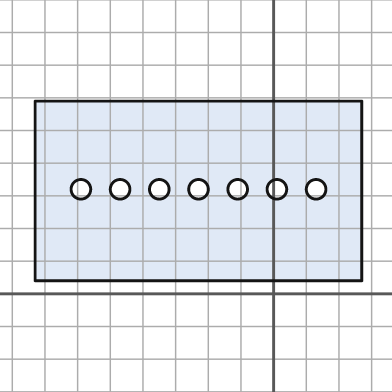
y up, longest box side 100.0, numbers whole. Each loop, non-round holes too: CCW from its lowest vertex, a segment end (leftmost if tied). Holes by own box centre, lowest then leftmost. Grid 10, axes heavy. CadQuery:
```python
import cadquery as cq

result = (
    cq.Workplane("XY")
    .moveTo(-73.0, 4.0)
    .lineTo(27.0, 4.0)
    .lineTo(27.0, 59.0)
    .lineTo(-73.0, 59.0)
    .close()
    .moveTo(-59.0, 32.0)
    .circle(3.0)
    .moveTo(-47.0, 32.0)
    .circle(3.0)
    .moveTo(-35.0, 32.0)
    .circle(3.0)
    .moveTo(-23.0, 32.0)
    .circle(3.0)
    .moveTo(-11.0, 32.0)
    .circle(3.0)
    .moveTo(1.0, 32.0)
    .circle(3.0)
    .moveTo(13.0, 32.0)
    .circle(3.0)
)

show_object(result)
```